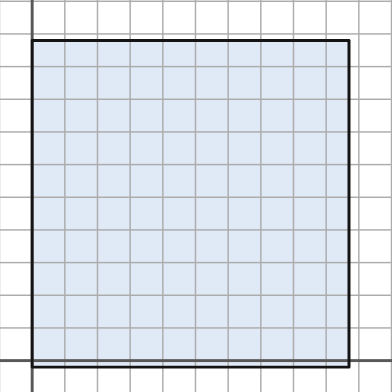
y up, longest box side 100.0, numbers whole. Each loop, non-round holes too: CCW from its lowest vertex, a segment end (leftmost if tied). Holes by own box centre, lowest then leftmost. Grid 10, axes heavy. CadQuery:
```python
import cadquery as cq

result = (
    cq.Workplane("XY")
    .moveTo(0.0, -2.0)
    .lineTo(97.0, -2.0)
    .lineTo(97.0, 98.0)
    .lineTo(0.0, 98.0)
    .close()
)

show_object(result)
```